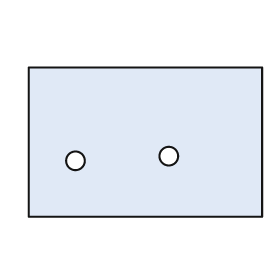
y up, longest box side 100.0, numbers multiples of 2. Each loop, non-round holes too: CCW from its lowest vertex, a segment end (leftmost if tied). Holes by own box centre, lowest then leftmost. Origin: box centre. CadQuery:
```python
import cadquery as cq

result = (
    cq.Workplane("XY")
    .moveTo(-50.0, -32.0)
    .lineTo(50.0, -32.0)
    .lineTo(50.0, 32.0)
    .lineTo(-50.0, 32.0)
    .close()
    .moveTo(-30.0, -8.0)
    .circle(4.0)
    .moveTo(10.0, -6.0)
    .circle(4.0)
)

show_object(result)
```